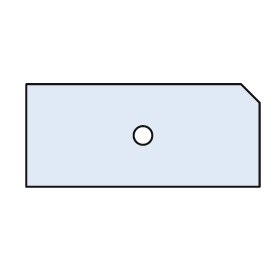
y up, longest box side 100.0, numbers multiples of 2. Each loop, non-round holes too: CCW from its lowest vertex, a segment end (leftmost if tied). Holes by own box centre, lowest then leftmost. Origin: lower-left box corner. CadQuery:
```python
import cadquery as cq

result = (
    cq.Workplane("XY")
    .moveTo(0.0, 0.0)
    .lineTo(100.0, 0.0)
    .lineTo(100.0, 36.0)
    .lineTo(92.0, 44.0)
    .lineTo(0.0, 44.0)
    .close()
    .moveTo(50.0, 22.0)
    .circle(4.0)
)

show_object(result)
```